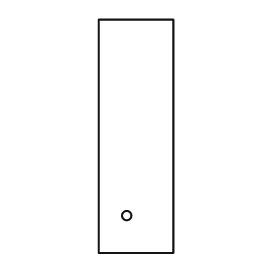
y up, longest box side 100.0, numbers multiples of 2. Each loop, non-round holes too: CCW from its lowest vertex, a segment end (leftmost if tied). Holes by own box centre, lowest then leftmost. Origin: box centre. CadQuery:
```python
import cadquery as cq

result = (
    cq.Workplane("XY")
    .moveTo(-16.0, -50.0)
    .lineTo(16.0, -50.0)
    .lineTo(16.0, 50.0)
    .lineTo(-16.0, 50.0)
    .close()
    .moveTo(-4.0, -34.0)
    .circle(2.0)
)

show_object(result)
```